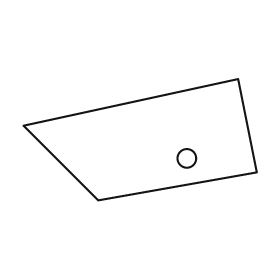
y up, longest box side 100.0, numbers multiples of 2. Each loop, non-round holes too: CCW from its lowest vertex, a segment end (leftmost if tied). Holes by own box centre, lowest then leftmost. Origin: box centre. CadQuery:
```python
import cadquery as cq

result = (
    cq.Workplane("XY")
    .moveTo(-18.0, -26.0)
    .lineTo(50.0, -14.0)
    .lineTo(42.0, 26.0)
    .lineTo(-50.0, 6.0)
    .close()
    .moveTo(20.0, -8.0)
    .circle(4.0)
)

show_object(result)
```